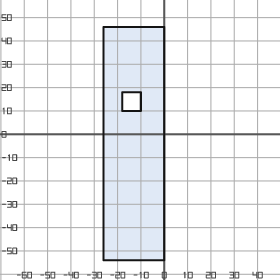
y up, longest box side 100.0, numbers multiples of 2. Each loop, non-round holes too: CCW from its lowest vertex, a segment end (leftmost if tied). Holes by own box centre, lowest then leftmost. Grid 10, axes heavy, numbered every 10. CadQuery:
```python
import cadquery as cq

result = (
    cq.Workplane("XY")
    .moveTo(-26.0, -54.0)
    .lineTo(0.0, -54.0)
    .lineTo(0.0, 46.0)
    .lineTo(-26.0, 46.0)
    .close()
    .moveTo(-18.0, 10.0)
    .lineTo(-10.0, 10.0)
    .lineTo(-10.0, 18.0)
    .lineTo(-18.0, 18.0)
    .close()
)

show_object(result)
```